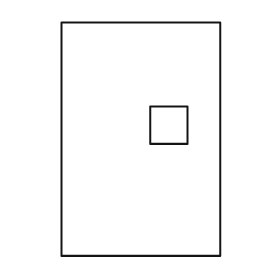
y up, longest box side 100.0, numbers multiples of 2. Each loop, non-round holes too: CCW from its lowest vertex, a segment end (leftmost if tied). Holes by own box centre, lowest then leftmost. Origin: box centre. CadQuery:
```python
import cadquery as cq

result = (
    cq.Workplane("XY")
    .moveTo(-34.0, -50.0)
    .lineTo(34.0, -50.0)
    .lineTo(34.0, 50.0)
    .lineTo(-34.0, 50.0)
    .close()
    .moveTo(4.0, -2.0)
    .lineTo(20.0, -2.0)
    .lineTo(20.0, 14.0)
    .lineTo(4.0, 14.0)
    .close()
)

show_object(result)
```